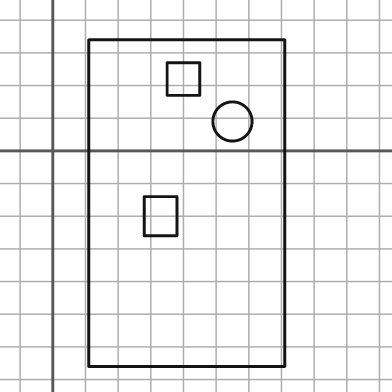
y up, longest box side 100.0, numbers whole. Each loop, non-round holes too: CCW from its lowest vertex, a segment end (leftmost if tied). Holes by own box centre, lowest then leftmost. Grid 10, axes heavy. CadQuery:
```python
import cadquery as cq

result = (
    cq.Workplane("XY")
    .moveTo(11.0, -66.0)
    .lineTo(71.0, -66.0)
    .lineTo(71.0, 34.0)
    .lineTo(11.0, 34.0)
    .close()
    .moveTo(28.0, -26.0)
    .lineTo(38.0, -26.0)
    .lineTo(38.0, -14.0)
    .lineTo(28.0, -14.0)
    .close()
    .moveTo(55.0, 9.0)
    .circle(6.0)
    .moveTo(35.0, 17.0)
    .lineTo(45.0, 17.0)
    .lineTo(45.0, 27.0)
    .lineTo(35.0, 27.0)
    .close()
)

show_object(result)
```